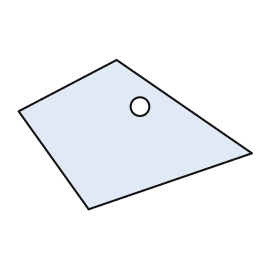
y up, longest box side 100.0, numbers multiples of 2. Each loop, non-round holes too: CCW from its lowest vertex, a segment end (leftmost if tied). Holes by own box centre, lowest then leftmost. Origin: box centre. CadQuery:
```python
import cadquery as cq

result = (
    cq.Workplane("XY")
    .moveTo(-20.0, -32.0)
    .lineTo(50.0, -8.0)
    .lineTo(-8.0, 32.0)
    .lineTo(-50.0, 10.0)
    .close()
    .moveTo(2.0, 12.0)
    .circle(4.0)
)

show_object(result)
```